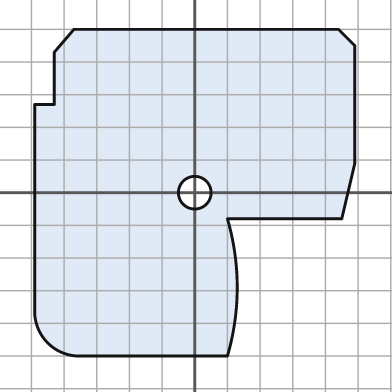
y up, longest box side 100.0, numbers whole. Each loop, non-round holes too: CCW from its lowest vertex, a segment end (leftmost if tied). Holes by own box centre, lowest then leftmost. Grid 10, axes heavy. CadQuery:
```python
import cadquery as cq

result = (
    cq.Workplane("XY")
    .moveTo(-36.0, -50.0)
    .lineTo(10.0, -50.0)
    .threePointArc((13.0, -29.0), (10.0, -8.0))
    .lineTo(45.0, -8.0)
    .lineTo(49.0, 9.0)
    .lineTo(49.0, 45.0)
    .lineTo(44.0, 50.0)
    .lineTo(-37.0, 50.0)
    .lineTo(-43.0, 43.0)
    .lineTo(-43.0, 27.0)
    .lineTo(-49.0, 27.0)
    .lineTo(-49.0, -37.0)
    .threePointArc((-45.0, -46.0), (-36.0, -50.0))
    .close()
    .moveTo(0.0, 0.0)
    .circle(5.0)
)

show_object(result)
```